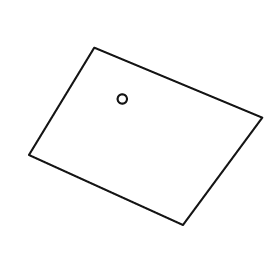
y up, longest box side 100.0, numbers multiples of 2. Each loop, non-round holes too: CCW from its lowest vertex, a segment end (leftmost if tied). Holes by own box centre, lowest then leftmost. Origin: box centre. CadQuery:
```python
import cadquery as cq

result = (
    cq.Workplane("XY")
    .moveTo(16.0, -38.0)
    .lineTo(50.0, 8.0)
    .lineTo(-22.0, 38.0)
    .lineTo(-50.0, -8.0)
    .close()
    .moveTo(-10.0, 16.0)
    .circle(2.0)
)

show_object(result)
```